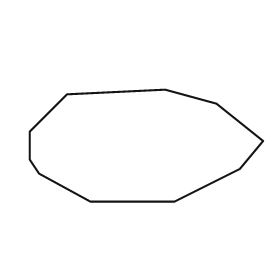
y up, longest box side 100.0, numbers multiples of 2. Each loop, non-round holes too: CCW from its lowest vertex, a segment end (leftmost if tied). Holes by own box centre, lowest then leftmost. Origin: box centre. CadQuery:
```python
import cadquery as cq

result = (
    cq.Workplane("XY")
    .moveTo(-24.0, -24.0)
    .lineTo(12.0, -24.0)
    .lineTo(40.0, -10.0)
    .lineTo(50.0, 2.0)
    .lineTo(30.0, 18.0)
    .lineTo(8.0, 24.0)
    .lineTo(-34.0, 22.0)
    .lineTo(-50.0, 6.0)
    .lineTo(-50.0, -6.0)
    .lineTo(-46.0, -12.0)
    .close()
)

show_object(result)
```